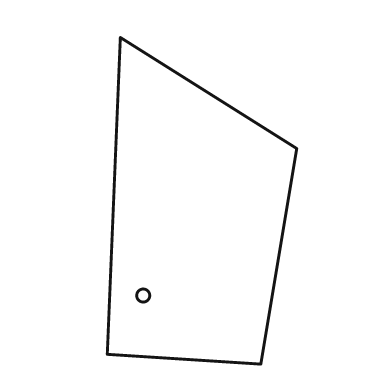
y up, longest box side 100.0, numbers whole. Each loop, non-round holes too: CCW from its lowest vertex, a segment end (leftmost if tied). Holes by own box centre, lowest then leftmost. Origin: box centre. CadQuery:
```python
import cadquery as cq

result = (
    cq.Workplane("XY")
    .moveTo(18.0, -50.0)
    .lineTo(29.0, 16.0)
    .lineTo(-25.0, 50.0)
    .lineTo(-29.0, -47.0)
    .close()
    .moveTo(-18.0, -29.0)
    .circle(2.0)
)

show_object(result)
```